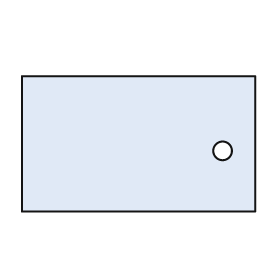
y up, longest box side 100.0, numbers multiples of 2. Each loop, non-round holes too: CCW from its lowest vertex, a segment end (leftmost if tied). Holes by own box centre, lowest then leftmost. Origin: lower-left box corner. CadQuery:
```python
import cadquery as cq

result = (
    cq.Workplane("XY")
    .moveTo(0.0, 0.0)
    .lineTo(100.0, 0.0)
    .lineTo(100.0, 58.0)
    .lineTo(0.0, 58.0)
    .close()
    .moveTo(86.0, 26.0)
    .circle(4.0)
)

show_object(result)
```